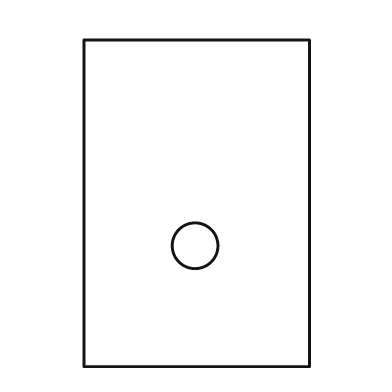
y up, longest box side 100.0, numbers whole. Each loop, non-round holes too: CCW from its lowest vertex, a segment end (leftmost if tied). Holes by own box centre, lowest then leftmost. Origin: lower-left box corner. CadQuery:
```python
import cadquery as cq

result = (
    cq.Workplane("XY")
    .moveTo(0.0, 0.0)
    .lineTo(69.0, 0.0)
    .lineTo(69.0, 100.0)
    .lineTo(0.0, 100.0)
    .close()
    .moveTo(34.0, 37.0)
    .circle(7.0)
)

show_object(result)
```